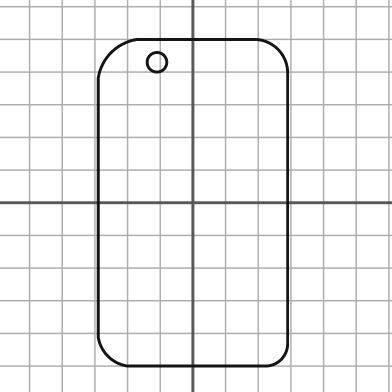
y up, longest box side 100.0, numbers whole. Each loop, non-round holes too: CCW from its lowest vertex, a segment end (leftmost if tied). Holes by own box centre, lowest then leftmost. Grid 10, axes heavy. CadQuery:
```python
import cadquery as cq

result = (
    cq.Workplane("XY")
    .moveTo(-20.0, -50.0)
    .lineTo(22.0, -50.0)
    .threePointArc((27.0, -48.0), (29.0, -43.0))
    .lineTo(29.0, 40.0)
    .threePointArc((26.0, 47.0), (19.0, 50.0))
    .lineTo(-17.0, 50.0)
    .threePointArc((-25.0, 46.0), (-29.0, 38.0))
    .lineTo(-29.0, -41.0)
    .threePointArc((-26.0, -47.0), (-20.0, -50.0))
    .close()
    .moveTo(-11.0, 43.0)
    .circle(3.0)
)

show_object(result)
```